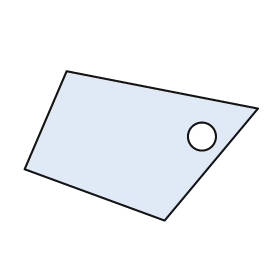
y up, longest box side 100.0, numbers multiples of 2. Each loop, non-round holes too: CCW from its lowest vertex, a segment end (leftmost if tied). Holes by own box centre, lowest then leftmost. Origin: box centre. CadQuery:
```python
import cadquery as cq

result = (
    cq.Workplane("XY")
    .moveTo(10.0, -32.0)
    .lineTo(50.0, 16.0)
    .lineTo(-32.0, 32.0)
    .lineTo(-50.0, -10.0)
    .close()
    .moveTo(26.0, 4.0)
    .circle(6.0)
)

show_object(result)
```